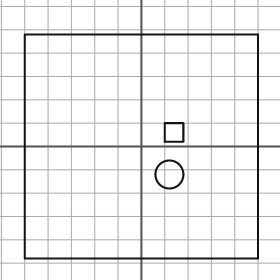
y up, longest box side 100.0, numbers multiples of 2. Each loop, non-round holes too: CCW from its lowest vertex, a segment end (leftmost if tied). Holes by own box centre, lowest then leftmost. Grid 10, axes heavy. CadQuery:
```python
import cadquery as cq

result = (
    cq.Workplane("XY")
    .moveTo(-50.0, -48.0)
    .lineTo(50.0, -48.0)
    .lineTo(50.0, 48.0)
    .lineTo(-50.0, 48.0)
    .close()
    .moveTo(12.0, -12.0)
    .circle(6.0)
    .moveTo(10.0, 2.0)
    .lineTo(18.0, 2.0)
    .lineTo(18.0, 10.0)
    .lineTo(10.0, 10.0)
    .close()
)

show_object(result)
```